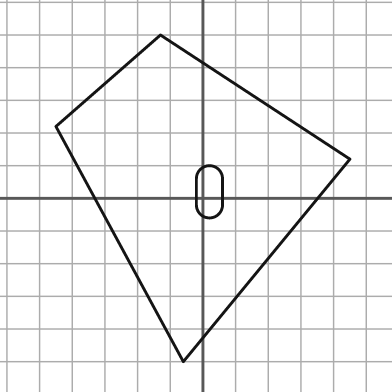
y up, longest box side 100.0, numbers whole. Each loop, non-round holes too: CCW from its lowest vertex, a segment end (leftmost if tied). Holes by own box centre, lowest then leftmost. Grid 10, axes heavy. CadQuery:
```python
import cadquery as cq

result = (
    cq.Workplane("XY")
    .moveTo(-6.0, -50.0)
    .lineTo(45.0, 12.0)
    .lineTo(-13.0, 50.0)
    .lineTo(-45.0, 22.0)
    .close()
    .moveTo(-2.0, -2.0)
    .threePointArc((2.0, -6.0), (6.0, -2.0))
    .lineTo(6.0, 6.0)
    .threePointArc((2.0, 10.0), (-2.0, 6.0))
    .close()
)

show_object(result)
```